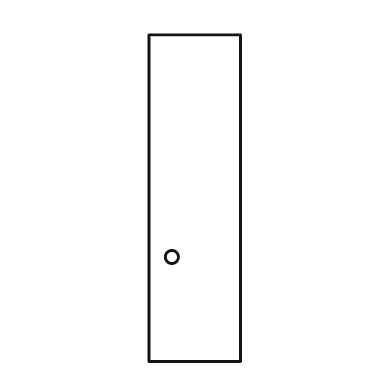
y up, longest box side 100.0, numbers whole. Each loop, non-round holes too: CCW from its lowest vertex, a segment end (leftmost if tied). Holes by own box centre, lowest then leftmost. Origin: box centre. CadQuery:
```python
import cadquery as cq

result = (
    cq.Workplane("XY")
    .moveTo(-14.0, -50.0)
    .lineTo(14.0, -50.0)
    .lineTo(14.0, 50.0)
    .lineTo(-14.0, 50.0)
    .close()
    .moveTo(-7.0, -18.0)
    .circle(2.0)
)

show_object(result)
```